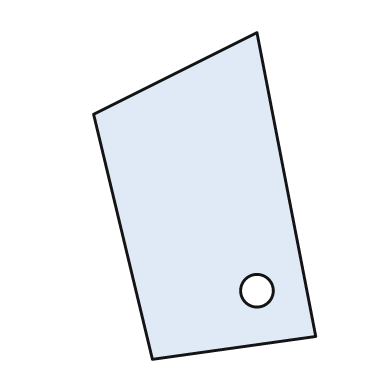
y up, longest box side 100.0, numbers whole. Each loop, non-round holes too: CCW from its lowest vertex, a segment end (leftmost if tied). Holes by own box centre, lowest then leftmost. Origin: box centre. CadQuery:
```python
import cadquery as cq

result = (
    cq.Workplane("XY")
    .moveTo(-16.0, -50.0)
    .lineTo(34.0, -43.0)
    .lineTo(16.0, 50.0)
    .lineTo(-34.0, 25.0)
    .close()
    .moveTo(16.0, -29.0)
    .circle(5.0)
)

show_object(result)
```